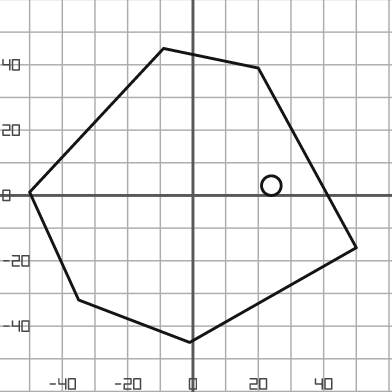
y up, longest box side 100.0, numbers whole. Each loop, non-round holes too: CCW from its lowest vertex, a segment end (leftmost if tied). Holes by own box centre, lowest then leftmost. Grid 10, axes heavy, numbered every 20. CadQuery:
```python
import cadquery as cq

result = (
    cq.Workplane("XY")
    .moveTo(-1.0, -45.0)
    .lineTo(50.0, -16.0)
    .lineTo(20.0, 39.0)
    .lineTo(-9.0, 45.0)
    .lineTo(-50.0, 1.0)
    .lineTo(-35.0, -32.0)
    .close()
    .moveTo(24.0, 3.0)
    .circle(3.0)
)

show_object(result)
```